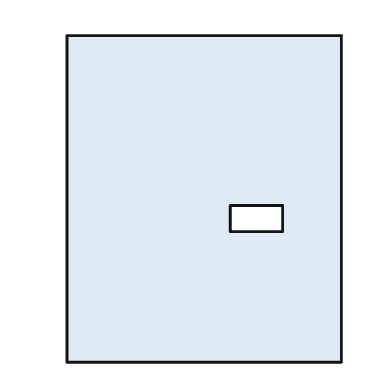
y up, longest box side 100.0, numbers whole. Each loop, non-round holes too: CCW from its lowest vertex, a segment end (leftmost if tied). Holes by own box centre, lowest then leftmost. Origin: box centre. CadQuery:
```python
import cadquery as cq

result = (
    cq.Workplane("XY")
    .moveTo(-42.0, -50.0)
    .lineTo(42.0, -50.0)
    .lineTo(42.0, 50.0)
    .lineTo(-42.0, 50.0)
    .close()
    .moveTo(8.0, -10.0)
    .lineTo(24.0, -10.0)
    .lineTo(24.0, -2.0)
    .lineTo(8.0, -2.0)
    .close()
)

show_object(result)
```